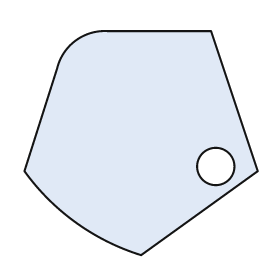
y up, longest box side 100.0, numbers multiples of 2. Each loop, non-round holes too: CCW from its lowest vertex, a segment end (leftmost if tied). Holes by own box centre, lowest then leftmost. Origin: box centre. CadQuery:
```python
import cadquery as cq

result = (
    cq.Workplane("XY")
    .moveTo(0.0, -48.0)
    .lineTo(50.0, -12.0)
    .lineTo(30.0, 48.0)
    .lineTo(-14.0, 48.0)
    .threePointArc((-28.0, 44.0), (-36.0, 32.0))
    .lineTo(-50.0, -12.0)
    .threePointArc((-28.0, -34.0), (0.0, -48.0))
    .close()
    .moveTo(32.0, -10.0)
    .circle(8.0)
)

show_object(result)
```